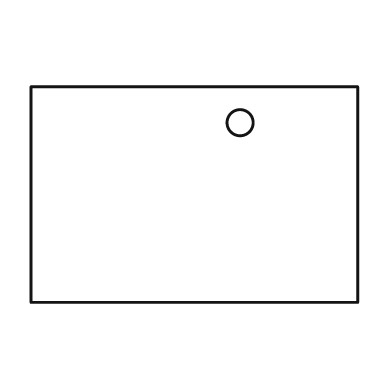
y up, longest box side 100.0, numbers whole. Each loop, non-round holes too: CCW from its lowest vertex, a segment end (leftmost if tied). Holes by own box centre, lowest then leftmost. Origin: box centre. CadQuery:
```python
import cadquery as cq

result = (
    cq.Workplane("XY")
    .moveTo(-50.0, -33.0)
    .lineTo(50.0, -33.0)
    .lineTo(50.0, 33.0)
    .lineTo(-50.0, 33.0)
    .close()
    .moveTo(14.0, 22.0)
    .circle(4.0)
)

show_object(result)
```